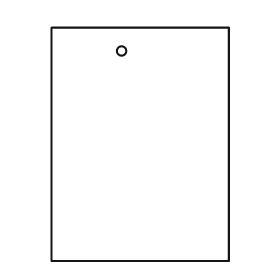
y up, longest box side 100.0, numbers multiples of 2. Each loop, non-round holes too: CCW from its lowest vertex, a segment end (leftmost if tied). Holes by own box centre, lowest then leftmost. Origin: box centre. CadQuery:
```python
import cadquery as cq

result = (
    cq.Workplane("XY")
    .moveTo(-38.0, -50.0)
    .lineTo(38.0, -50.0)
    .lineTo(38.0, 50.0)
    .lineTo(-38.0, 50.0)
    .close()
    .moveTo(-8.0, 40.0)
    .circle(2.0)
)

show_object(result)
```